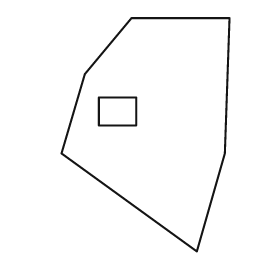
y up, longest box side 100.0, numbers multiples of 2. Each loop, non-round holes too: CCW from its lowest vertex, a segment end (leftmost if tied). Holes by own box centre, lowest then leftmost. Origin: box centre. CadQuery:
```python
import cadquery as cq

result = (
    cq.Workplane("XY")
    .moveTo(22.0, -50.0)
    .lineTo(34.0, -8.0)
    .lineTo(36.0, 50.0)
    .lineTo(-6.0, 50.0)
    .lineTo(-26.0, 26.0)
    .lineTo(-36.0, -8.0)
    .close()
    .moveTo(-20.0, 4.0)
    .lineTo(-4.0, 4.0)
    .lineTo(-4.0, 16.0)
    .lineTo(-20.0, 16.0)
    .close()
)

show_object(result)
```